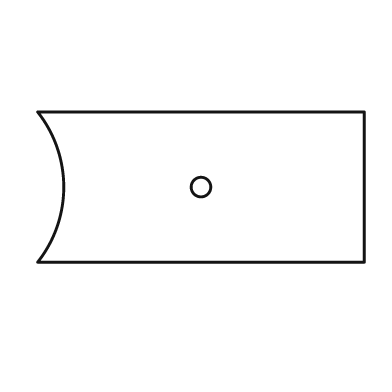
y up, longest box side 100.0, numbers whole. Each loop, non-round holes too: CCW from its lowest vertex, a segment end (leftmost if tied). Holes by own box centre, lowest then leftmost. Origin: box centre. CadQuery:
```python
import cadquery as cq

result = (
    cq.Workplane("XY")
    .moveTo(-50.0, -23.0)
    .lineTo(50.0, -23.0)
    .lineTo(50.0, 23.0)
    .lineTo(-50.0, 23.0)
    .threePointArc((-42.0, 0.0), (-50.0, -23.0))
    .close()
    .moveTo(0.0, 0.0)
    .circle(3.0)
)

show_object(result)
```